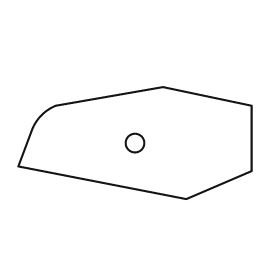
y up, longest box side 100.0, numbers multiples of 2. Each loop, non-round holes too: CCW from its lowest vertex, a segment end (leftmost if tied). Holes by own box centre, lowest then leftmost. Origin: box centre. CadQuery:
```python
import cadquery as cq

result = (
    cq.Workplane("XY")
    .moveTo(22.0, -24.0)
    .lineTo(50.0, -12.0)
    .lineTo(50.0, 16.0)
    .lineTo(12.0, 24.0)
    .lineTo(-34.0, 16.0)
    .threePointArc((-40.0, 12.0), (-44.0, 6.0))
    .lineTo(-50.0, -10.0)
    .close()
    .moveTo(0.0, 0.0)
    .circle(4.0)
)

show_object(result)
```